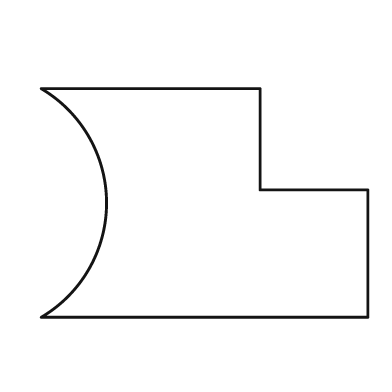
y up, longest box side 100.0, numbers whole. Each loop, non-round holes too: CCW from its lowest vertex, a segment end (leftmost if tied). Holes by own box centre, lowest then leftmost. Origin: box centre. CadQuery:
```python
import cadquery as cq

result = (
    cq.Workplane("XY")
    .moveTo(-50.0, -35.0)
    .lineTo(50.0, -35.0)
    .lineTo(50.0, 4.0)
    .lineTo(17.0, 4.0)
    .lineTo(17.0, 35.0)
    .lineTo(-50.0, 35.0)
    .threePointArc((-30.0, 0.0), (-50.0, -35.0))
    .close()
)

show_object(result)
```